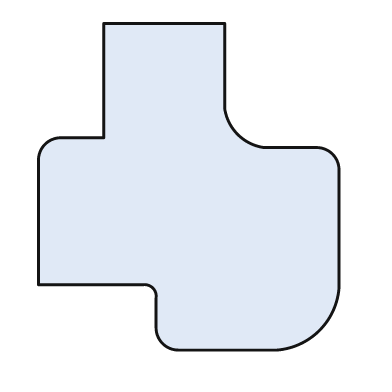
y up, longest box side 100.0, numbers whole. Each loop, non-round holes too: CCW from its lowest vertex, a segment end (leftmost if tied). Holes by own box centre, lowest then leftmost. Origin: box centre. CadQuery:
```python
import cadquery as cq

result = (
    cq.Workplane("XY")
    .moveTo(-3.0, -50.0)
    .lineTo(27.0, -50.0)
    .threePointArc((40.0, -44.0), (46.0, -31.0))
    .lineTo(46.0, 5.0)
    .threePointArc((44.0, 10.0), (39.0, 12.0))
    .lineTo(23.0, 12.0)
    .threePointArc((15.0, 16.0), (11.0, 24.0))
    .lineTo(11.0, 50.0)
    .lineTo(-26.0, 50.0)
    .lineTo(-26.0, 15.0)
    .lineTo(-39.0, 15.0)
    .threePointArc((-44.0, 13.0), (-46.0, 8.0))
    .lineTo(-46.0, -30.0)
    .lineTo(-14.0, -30.0)
    .threePointArc((-11.0, -31.0), (-10.0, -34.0))
    .lineTo(-10.0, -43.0)
    .threePointArc((-8.0, -48.0), (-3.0, -50.0))
    .close()
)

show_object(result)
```